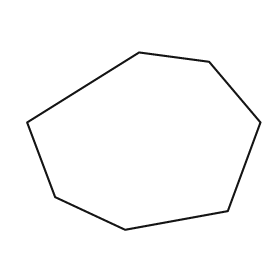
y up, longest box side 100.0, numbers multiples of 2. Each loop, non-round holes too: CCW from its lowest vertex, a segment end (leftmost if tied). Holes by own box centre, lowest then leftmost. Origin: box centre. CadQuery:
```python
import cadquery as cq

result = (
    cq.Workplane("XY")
    .moveTo(-8.0, -38.0)
    .lineTo(36.0, -30.0)
    .lineTo(50.0, 8.0)
    .lineTo(28.0, 34.0)
    .lineTo(-2.0, 38.0)
    .lineTo(-50.0, 8.0)
    .lineTo(-38.0, -24.0)
    .close()
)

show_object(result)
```